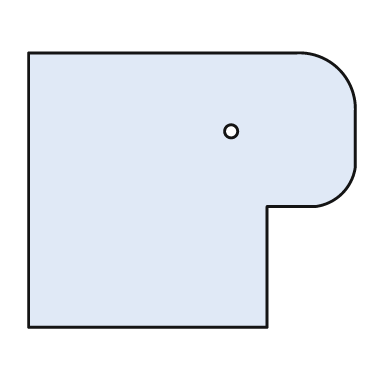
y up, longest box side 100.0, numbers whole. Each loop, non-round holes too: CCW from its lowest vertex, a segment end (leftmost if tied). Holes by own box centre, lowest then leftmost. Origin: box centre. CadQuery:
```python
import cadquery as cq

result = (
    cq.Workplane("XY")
    .moveTo(-50.0, -42.0)
    .lineTo(23.0, -42.0)
    .lineTo(23.0, -5.0)
    .lineTo(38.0, -5.0)
    .threePointArc((46.0, -1.0), (50.0, 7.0))
    .lineTo(50.0, 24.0)
    .threePointArc((45.0, 37.0), (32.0, 42.0))
    .lineTo(-50.0, 42.0)
    .close()
    .moveTo(12.0, 18.0)
    .circle(2.0)
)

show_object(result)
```